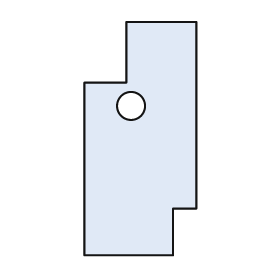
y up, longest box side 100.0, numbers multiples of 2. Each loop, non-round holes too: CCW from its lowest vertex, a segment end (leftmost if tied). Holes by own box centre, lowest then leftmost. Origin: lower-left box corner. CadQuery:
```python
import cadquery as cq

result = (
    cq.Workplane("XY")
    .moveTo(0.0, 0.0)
    .lineTo(38.0, 0.0)
    .lineTo(38.0, 20.0)
    .lineTo(48.0, 20.0)
    .lineTo(48.0, 100.0)
    .lineTo(18.0, 100.0)
    .lineTo(18.0, 74.0)
    .lineTo(0.0, 74.0)
    .close()
    .moveTo(20.0, 64.0)
    .circle(6.0)
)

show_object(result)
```